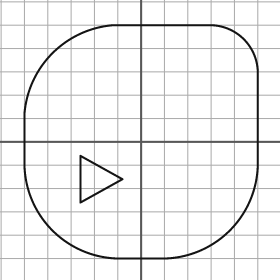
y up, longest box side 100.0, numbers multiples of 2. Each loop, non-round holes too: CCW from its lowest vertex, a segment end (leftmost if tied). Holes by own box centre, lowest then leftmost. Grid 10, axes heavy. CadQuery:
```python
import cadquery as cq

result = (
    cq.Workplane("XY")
    .moveTo(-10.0, -50.0)
    .lineTo(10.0, -50.0)
    .threePointArc((38.0, -38.0), (50.0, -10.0))
    .lineTo(50.0, 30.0)
    .threePointArc((44.0, 44.0), (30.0, 50.0))
    .lineTo(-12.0, 50.0)
    .threePointArc((-38.0, 38.0), (-50.0, 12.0))
    .lineTo(-50.0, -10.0)
    .threePointArc((-38.0, -38.0), (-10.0, -50.0))
    .close()
    .moveTo(-26.0, -26.0)
    .lineTo(-8.0, -16.0)
    .lineTo(-26.0, -6.0)
    .close()
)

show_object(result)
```